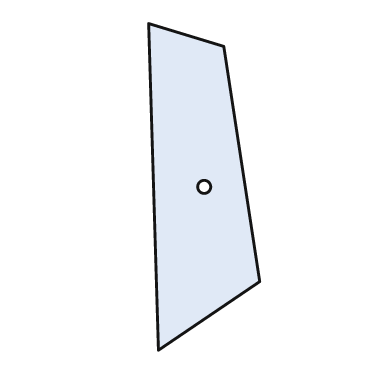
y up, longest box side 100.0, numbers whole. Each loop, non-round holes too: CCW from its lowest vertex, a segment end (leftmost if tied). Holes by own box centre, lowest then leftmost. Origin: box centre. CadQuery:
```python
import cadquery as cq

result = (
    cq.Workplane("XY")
    .moveTo(-14.0, -50.0)
    .lineTo(17.0, -29.0)
    .lineTo(6.0, 43.0)
    .lineTo(-17.0, 50.0)
    .close()
    .moveTo(0.0, 0.0)
    .circle(2.0)
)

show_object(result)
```